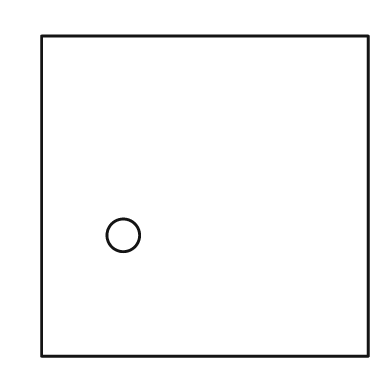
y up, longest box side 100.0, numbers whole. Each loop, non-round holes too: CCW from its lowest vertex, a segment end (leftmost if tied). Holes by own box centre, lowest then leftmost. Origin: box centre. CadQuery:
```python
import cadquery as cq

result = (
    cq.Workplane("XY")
    .moveTo(-50.0, -49.0)
    .lineTo(50.0, -49.0)
    .lineTo(50.0, 49.0)
    .lineTo(-50.0, 49.0)
    .close()
    .moveTo(-25.0, -12.0)
    .circle(5.0)
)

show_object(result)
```